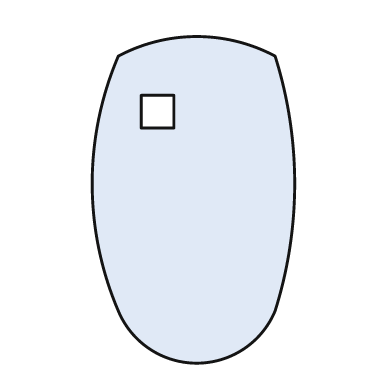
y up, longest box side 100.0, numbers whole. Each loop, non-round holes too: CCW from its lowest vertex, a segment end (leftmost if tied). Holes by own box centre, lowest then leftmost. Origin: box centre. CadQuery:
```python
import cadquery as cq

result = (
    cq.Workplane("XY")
    .moveTo(-23.0, -34.0)
    .threePointArc((1.0, -50.0), (25.0, -34.0))
    .threePointArc((31.0, 5.0), (25.0, 44.0))
    .threePointArc((1.0, 50.0), (-23.0, 44.0))
    .threePointArc((-31.0, 5.0), (-23.0, -34.0))
    .close()
    .moveTo(-16.0, 22.0)
    .lineTo(-6.0, 22.0)
    .lineTo(-6.0, 32.0)
    .lineTo(-16.0, 32.0)
    .close()
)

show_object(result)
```